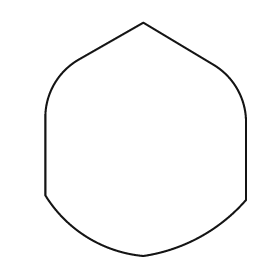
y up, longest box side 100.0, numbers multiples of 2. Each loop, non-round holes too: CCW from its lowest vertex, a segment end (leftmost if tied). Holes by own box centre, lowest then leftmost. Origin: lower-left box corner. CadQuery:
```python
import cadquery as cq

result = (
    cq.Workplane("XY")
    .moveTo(42.0, 0.0)
    .threePointArc((66.0, 8.0), (86.0, 24.0))
    .lineTo(86.0, 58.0)
    .threePointArc((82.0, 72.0), (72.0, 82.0))
    .lineTo(42.0, 100.0)
    .lineTo(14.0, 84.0)
    .threePointArc((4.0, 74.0), (0.0, 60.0))
    .lineTo(0.0, 26.0)
    .threePointArc((18.0, 8.0), (42.0, 0.0))
    .close()
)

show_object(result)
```